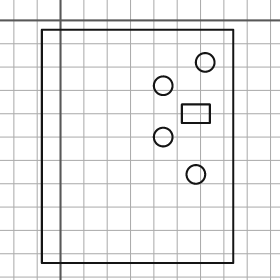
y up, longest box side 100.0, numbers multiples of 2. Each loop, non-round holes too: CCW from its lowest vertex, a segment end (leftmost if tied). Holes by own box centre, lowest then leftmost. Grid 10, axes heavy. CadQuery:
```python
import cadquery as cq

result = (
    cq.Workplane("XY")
    .moveTo(-8.0, -104.0)
    .lineTo(74.0, -104.0)
    .lineTo(74.0, -4.0)
    .lineTo(-8.0, -4.0)
    .close()
    .moveTo(58.0, -66.0)
    .circle(4.0)
    .moveTo(44.0, -50.0)
    .circle(4.0)
    .moveTo(52.0, -44.0)
    .lineTo(64.0, -44.0)
    .lineTo(64.0, -36.0)
    .lineTo(52.0, -36.0)
    .close()
    .moveTo(44.0, -28.0)
    .circle(4.0)
    .moveTo(62.0, -18.0)
    .circle(4.0)
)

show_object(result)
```